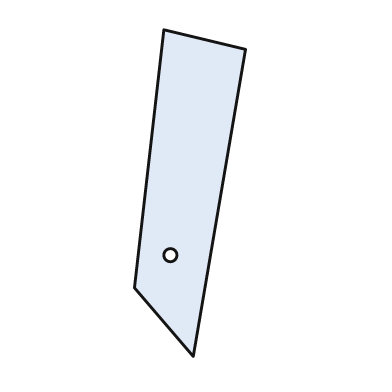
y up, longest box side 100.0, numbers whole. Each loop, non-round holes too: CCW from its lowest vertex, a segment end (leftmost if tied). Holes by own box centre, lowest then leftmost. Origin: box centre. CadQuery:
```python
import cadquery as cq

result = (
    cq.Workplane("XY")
    .moveTo(1.0, -50.0)
    .lineTo(17.0, 44.0)
    .lineTo(-8.0, 50.0)
    .lineTo(-17.0, -29.0)
    .close()
    .moveTo(-6.0, -19.0)
    .circle(2.0)
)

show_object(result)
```